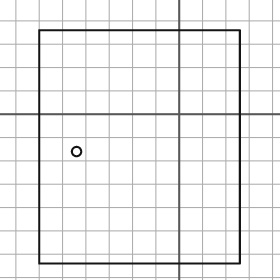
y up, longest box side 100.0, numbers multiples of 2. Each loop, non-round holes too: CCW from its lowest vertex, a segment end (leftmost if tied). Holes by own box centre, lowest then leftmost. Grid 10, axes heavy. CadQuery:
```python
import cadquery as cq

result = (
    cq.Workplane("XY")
    .moveTo(-60.0, -64.0)
    .lineTo(26.0, -64.0)
    .lineTo(26.0, 36.0)
    .lineTo(-60.0, 36.0)
    .close()
    .moveTo(-44.0, -16.0)
    .circle(2.0)
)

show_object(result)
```